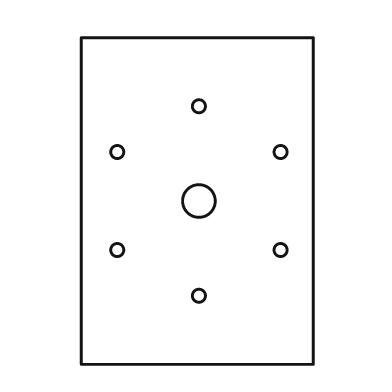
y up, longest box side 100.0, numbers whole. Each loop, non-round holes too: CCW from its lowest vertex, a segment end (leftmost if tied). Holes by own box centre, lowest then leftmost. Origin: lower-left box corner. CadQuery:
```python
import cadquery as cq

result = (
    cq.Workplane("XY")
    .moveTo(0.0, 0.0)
    .lineTo(71.0, 0.0)
    .lineTo(71.0, 100.0)
    .lineTo(0.0, 100.0)
    .close()
    .moveTo(36.0, 21.0)
    .circle(2.0)
    .moveTo(11.0, 35.0)
    .circle(2.0)
    .moveTo(61.0, 35.0)
    .circle(2.0)
    .moveTo(36.0, 50.0)
    .circle(5.0)
    .moveTo(11.0, 65.0)
    .circle(2.0)
    .moveTo(61.0, 65.0)
    .circle(2.0)
    .moveTo(36.0, 79.0)
    .circle(2.0)
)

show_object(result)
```